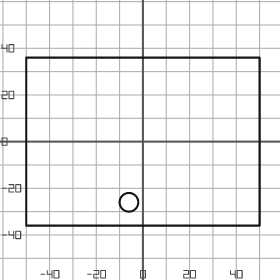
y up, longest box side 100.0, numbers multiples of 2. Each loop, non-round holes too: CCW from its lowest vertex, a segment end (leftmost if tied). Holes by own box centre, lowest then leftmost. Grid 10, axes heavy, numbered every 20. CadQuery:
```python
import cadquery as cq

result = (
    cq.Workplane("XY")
    .moveTo(-50.0, -36.0)
    .lineTo(50.0, -36.0)
    .lineTo(50.0, 36.0)
    .lineTo(-50.0, 36.0)
    .close()
    .moveTo(-6.0, -26.0)
    .circle(4.0)
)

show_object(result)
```